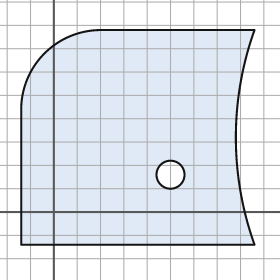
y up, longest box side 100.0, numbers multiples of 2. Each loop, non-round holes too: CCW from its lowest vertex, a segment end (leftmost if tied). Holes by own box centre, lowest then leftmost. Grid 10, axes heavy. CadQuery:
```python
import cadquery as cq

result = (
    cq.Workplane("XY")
    .moveTo(-14.0, -14.0)
    .lineTo(86.0, -14.0)
    .threePointArc((78.0, 32.0), (86.0, 78.0))
    .lineTo(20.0, 78.0)
    .threePointArc((-4.0, 68.0), (-14.0, 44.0))
    .close()
    .moveTo(50.0, 16.0)
    .circle(6.0)
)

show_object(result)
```